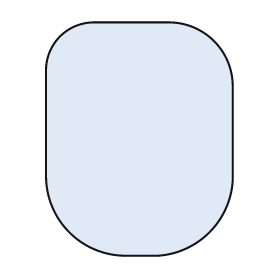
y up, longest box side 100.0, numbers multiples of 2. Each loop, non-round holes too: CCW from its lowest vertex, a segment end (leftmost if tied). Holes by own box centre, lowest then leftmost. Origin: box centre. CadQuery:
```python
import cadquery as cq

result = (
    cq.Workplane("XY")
    .moveTo(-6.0, -50.0)
    .lineTo(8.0, -50.0)
    .threePointArc((30.0, -40.0), (40.0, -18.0))
    .lineTo(40.0, 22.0)
    .threePointArc((32.0, 42.0), (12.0, 50.0))
    .lineTo(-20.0, 50.0)
    .threePointArc((-34.0, 44.0), (-40.0, 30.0))
    .lineTo(-40.0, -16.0)
    .threePointArc((-30.0, -40.0), (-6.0, -50.0))
    .close()
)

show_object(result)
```